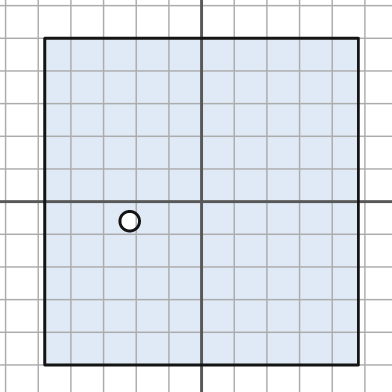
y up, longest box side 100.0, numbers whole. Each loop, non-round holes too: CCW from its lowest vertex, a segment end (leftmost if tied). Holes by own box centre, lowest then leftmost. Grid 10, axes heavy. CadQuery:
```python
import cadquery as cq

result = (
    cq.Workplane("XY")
    .moveTo(-48.0, -50.0)
    .lineTo(48.0, -50.0)
    .lineTo(48.0, 50.0)
    .lineTo(-48.0, 50.0)
    .close()
    .moveTo(-22.0, -6.0)
    .circle(3.0)
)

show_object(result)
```